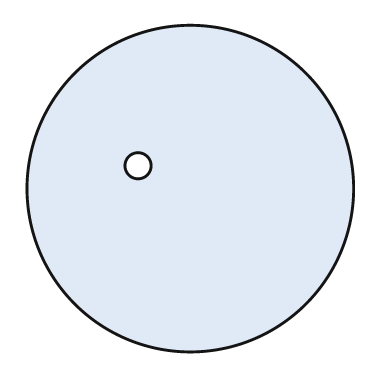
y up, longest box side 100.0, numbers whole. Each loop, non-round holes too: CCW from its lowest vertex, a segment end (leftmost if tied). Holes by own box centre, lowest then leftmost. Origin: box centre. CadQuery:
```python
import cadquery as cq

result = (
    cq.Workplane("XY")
    .moveTo(0.0, 0.0)
    .circle(50.0)
    .moveTo(-16.0, 7.0)
    .circle(4.0)
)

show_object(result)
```